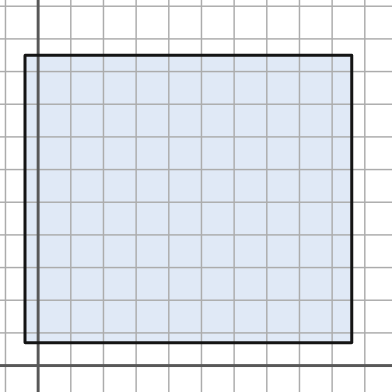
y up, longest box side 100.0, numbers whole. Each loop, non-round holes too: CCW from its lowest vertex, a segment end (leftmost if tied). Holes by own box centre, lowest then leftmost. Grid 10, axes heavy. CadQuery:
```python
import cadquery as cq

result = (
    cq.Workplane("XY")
    .moveTo(-4.0, 7.0)
    .lineTo(96.0, 7.0)
    .lineTo(96.0, 95.0)
    .lineTo(-4.0, 95.0)
    .close()
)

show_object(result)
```